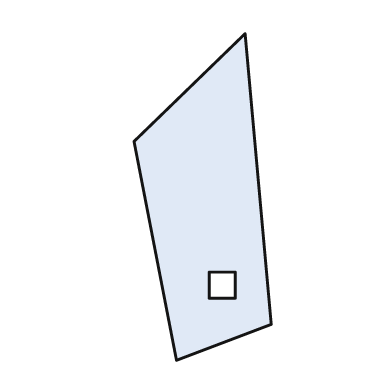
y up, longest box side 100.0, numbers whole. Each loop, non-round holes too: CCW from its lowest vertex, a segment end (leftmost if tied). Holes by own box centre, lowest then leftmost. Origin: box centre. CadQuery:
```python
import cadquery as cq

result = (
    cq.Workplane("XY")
    .moveTo(-8.0, -50.0)
    .lineTo(21.0, -39.0)
    .lineTo(13.0, 50.0)
    .lineTo(-21.0, 17.0)
    .close()
    .moveTo(2.0, -31.0)
    .lineTo(10.0, -31.0)
    .lineTo(10.0, -23.0)
    .lineTo(2.0, -23.0)
    .close()
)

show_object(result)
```